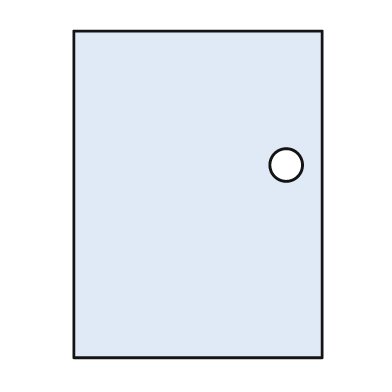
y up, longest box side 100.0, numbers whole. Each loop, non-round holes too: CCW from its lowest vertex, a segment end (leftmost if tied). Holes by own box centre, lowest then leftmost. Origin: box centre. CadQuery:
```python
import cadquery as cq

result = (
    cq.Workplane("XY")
    .moveTo(-38.0, -50.0)
    .lineTo(38.0, -50.0)
    .lineTo(38.0, 50.0)
    .lineTo(-38.0, 50.0)
    .close()
    .moveTo(27.0, 9.0)
    .circle(5.0)
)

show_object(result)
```